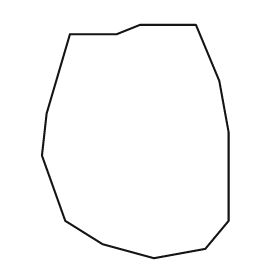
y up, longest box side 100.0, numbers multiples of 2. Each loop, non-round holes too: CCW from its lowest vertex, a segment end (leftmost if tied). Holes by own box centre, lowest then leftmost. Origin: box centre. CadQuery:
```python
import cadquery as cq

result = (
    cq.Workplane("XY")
    .moveTo(8.0, -50.0)
    .lineTo(30.0, -46.0)
    .lineTo(40.0, -34.0)
    .lineTo(40.0, 4.0)
    .lineTo(36.0, 26.0)
    .lineTo(26.0, 50.0)
    .lineTo(2.0, 50.0)
    .lineTo(-8.0, 46.0)
    .lineTo(-28.0, 46.0)
    .lineTo(-38.0, 12.0)
    .lineTo(-40.0, -6.0)
    .lineTo(-30.0, -34.0)
    .lineTo(-14.0, -44.0)
    .close()
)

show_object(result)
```